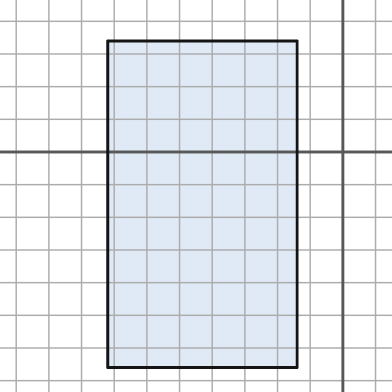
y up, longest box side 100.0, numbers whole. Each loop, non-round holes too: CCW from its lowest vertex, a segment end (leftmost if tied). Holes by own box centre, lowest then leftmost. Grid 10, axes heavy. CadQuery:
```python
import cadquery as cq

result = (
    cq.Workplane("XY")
    .moveTo(-72.0, -66.0)
    .lineTo(-14.0, -66.0)
    .lineTo(-14.0, 34.0)
    .lineTo(-72.0, 34.0)
    .close()
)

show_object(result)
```